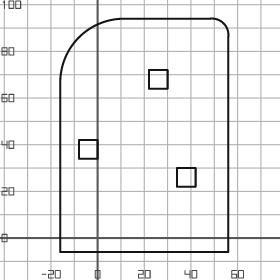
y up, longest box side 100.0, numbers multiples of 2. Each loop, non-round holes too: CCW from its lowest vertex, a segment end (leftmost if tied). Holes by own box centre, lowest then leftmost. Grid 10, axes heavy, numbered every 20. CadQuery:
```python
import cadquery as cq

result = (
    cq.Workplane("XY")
    .moveTo(-16.0, -6.0)
    .lineTo(56.0, -6.0)
    .lineTo(56.0, 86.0)
    .threePointArc((54.0, 92.0), (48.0, 94.0))
    .lineTo(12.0, 94.0)
    .threePointArc((-8.0, 86.0), (-16.0, 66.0))
    .close()
    .moveTo(34.0, 22.0)
    .lineTo(42.0, 22.0)
    .lineTo(42.0, 30.0)
    .lineTo(34.0, 30.0)
    .close()
    .moveTo(-8.0, 34.0)
    .lineTo(0.0, 34.0)
    .lineTo(0.0, 42.0)
    .lineTo(-8.0, 42.0)
    .close()
    .moveTo(22.0, 64.0)
    .lineTo(30.0, 64.0)
    .lineTo(30.0, 72.0)
    .lineTo(22.0, 72.0)
    .close()
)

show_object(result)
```